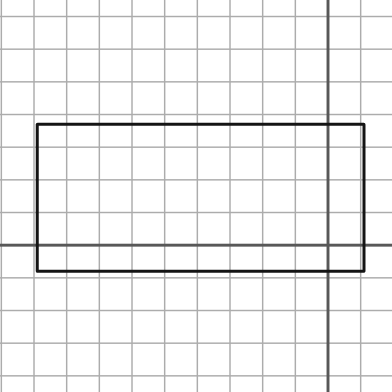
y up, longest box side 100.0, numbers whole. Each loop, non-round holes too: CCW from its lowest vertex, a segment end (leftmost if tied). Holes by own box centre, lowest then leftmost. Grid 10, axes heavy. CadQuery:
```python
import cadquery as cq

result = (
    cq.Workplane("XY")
    .moveTo(-89.0, -8.0)
    .lineTo(11.0, -8.0)
    .lineTo(11.0, 37.0)
    .lineTo(-89.0, 37.0)
    .close()
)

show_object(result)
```